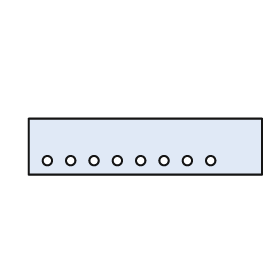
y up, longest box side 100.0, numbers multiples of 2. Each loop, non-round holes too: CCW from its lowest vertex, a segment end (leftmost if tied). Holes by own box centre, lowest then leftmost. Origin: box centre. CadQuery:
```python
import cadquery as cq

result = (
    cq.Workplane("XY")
    .moveTo(-50.0, -12.0)
    .lineTo(50.0, -12.0)
    .lineTo(50.0, 12.0)
    .lineTo(-50.0, 12.0)
    .close()
    .moveTo(-42.0, -6.0)
    .circle(2.0)
    .moveTo(-32.0, -6.0)
    .circle(2.0)
    .moveTo(-22.0, -6.0)
    .circle(2.0)
    .moveTo(-12.0, -6.0)
    .circle(2.0)
    .moveTo(-2.0, -6.0)
    .circle(2.0)
    .moveTo(8.0, -6.0)
    .circle(2.0)
    .moveTo(18.0, -6.0)
    .circle(2.0)
    .moveTo(28.0, -6.0)
    .circle(2.0)
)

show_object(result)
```